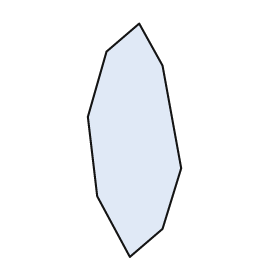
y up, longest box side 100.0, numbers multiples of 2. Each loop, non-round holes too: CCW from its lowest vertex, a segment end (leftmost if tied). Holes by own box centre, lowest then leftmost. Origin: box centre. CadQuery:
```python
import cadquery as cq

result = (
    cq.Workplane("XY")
    .moveTo(-2.0, -50.0)
    .lineTo(12.0, -38.0)
    .lineTo(20.0, -12.0)
    .lineTo(12.0, 32.0)
    .lineTo(2.0, 50.0)
    .lineTo(-12.0, 38.0)
    .lineTo(-20.0, 10.0)
    .lineTo(-16.0, -24.0)
    .close()
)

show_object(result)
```